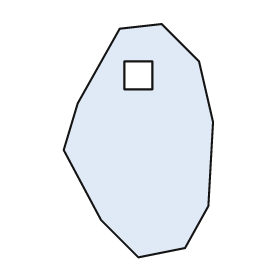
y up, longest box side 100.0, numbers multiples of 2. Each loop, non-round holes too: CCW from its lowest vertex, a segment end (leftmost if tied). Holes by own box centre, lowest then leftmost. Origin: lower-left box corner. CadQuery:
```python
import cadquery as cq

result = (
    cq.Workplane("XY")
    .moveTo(32.0, 0.0)
    .lineTo(52.0, 4.0)
    .lineTo(62.0, 22.0)
    .lineTo(64.0, 58.0)
    .lineTo(58.0, 84.0)
    .lineTo(42.0, 100.0)
    .lineTo(24.0, 98.0)
    .lineTo(6.0, 66.0)
    .lineTo(0.0, 46.0)
    .lineTo(16.0, 16.0)
    .close()
    .moveTo(26.0, 72.0)
    .lineTo(38.0, 72.0)
    .lineTo(38.0, 84.0)
    .lineTo(26.0, 84.0)
    .close()
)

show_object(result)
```